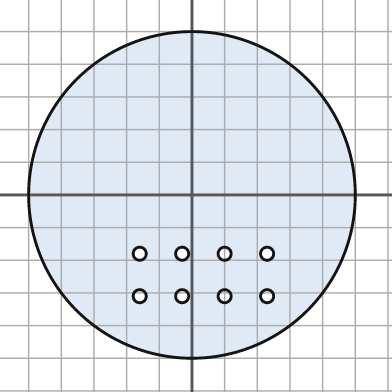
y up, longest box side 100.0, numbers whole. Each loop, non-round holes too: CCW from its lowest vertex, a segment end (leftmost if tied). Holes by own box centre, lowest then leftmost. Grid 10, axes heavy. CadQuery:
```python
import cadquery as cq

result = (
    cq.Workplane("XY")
    .moveTo(0.0, 0.0)
    .circle(50.0)
    .moveTo(-16.0, -31.0)
    .circle(2.0)
    .moveTo(-3.0, -31.0)
    .circle(2.0)
    .moveTo(10.0, -31.0)
    .circle(2.0)
    .moveTo(23.0, -31.0)
    .circle(2.0)
    .moveTo(-16.0, -18.0)
    .circle(2.0)
    .moveTo(-3.0, -18.0)
    .circle(2.0)
    .moveTo(10.0, -18.0)
    .circle(2.0)
    .moveTo(23.0, -18.0)
    .circle(2.0)
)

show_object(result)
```